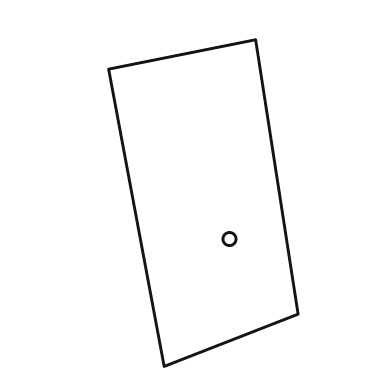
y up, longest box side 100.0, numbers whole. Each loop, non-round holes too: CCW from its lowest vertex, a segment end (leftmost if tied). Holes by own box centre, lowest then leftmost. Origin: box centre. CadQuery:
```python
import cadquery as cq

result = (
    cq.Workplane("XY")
    .moveTo(-12.0, -50.0)
    .lineTo(29.0, -34.0)
    .lineTo(16.0, 50.0)
    .lineTo(-29.0, 41.0)
    .close()
    .moveTo(8.0, -11.0)
    .circle(2.0)
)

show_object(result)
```